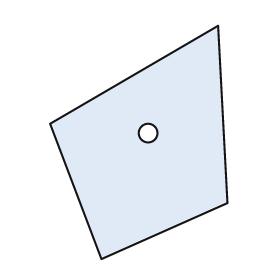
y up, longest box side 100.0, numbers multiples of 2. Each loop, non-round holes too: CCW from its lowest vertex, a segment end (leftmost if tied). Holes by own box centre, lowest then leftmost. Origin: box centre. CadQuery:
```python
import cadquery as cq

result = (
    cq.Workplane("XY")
    .moveTo(-16.0, -50.0)
    .lineTo(38.0, -26.0)
    .lineTo(34.0, 50.0)
    .lineTo(-38.0, 8.0)
    .close()
    .moveTo(4.0, 4.0)
    .circle(4.0)
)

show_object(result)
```